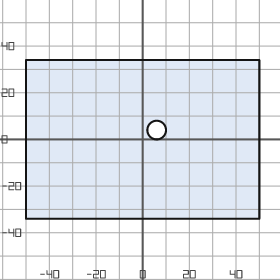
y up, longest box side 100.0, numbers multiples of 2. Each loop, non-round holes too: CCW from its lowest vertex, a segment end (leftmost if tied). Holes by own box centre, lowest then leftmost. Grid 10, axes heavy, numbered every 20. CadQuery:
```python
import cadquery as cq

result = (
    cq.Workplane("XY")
    .moveTo(-50.0, -34.0)
    .lineTo(50.0, -34.0)
    .lineTo(50.0, 34.0)
    .lineTo(-50.0, 34.0)
    .close()
    .moveTo(6.0, 4.0)
    .circle(4.0)
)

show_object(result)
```